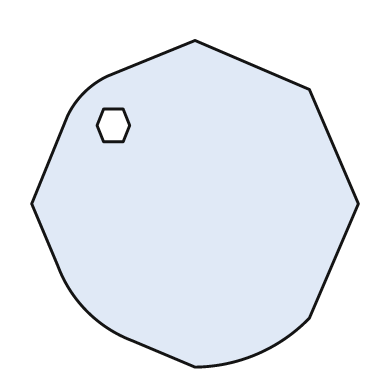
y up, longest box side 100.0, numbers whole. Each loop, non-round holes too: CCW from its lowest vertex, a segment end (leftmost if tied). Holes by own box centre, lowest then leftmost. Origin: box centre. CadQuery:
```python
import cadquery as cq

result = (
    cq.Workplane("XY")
    .moveTo(0.0, -50.0)
    .threePointArc((19.0, -46.0), (35.0, -35.0))
    .lineTo(50.0, 0.0)
    .lineTo(35.0, 35.0)
    .lineTo(0.0, 50.0)
    .lineTo(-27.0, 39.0)
    .threePointArc((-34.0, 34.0), (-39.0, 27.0))
    .lineTo(-50.0, 0.0)
    .lineTo(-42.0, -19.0)
    .threePointArc((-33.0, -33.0), (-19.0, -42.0))
    .close()
    .moveTo(-28.0, 19.0)
    .lineTo(-22.0, 19.0)
    .lineTo(-20.0, 24.0)
    .lineTo(-22.0, 29.0)
    .lineTo(-28.0, 29.0)
    .lineTo(-30.0, 24.0)
    .close()
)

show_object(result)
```